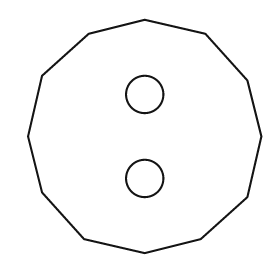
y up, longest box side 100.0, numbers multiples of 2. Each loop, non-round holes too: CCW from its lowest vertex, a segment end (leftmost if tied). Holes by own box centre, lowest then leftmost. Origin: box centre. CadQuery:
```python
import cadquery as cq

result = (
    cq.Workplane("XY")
    .moveTo(0.0, -50.0)
    .lineTo(24.0, -44.0)
    .lineTo(44.0, -26.0)
    .lineTo(50.0, 0.0)
    .lineTo(44.0, 24.0)
    .lineTo(26.0, 44.0)
    .lineTo(0.0, 50.0)
    .lineTo(-24.0, 44.0)
    .lineTo(-44.0, 26.0)
    .lineTo(-50.0, 0.0)
    .lineTo(-44.0, -24.0)
    .lineTo(-26.0, -44.0)
    .close()
    .moveTo(0.0, -18.0)
    .circle(8.0)
    .moveTo(0.0, 18.0)
    .circle(8.0)
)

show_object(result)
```